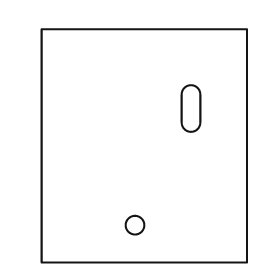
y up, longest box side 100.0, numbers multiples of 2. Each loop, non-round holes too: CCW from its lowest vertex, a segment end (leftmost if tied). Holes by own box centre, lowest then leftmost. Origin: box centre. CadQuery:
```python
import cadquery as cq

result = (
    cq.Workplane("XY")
    .moveTo(-44.0, -50.0)
    .lineTo(44.0, -50.0)
    .lineTo(44.0, 50.0)
    .lineTo(-44.0, 50.0)
    .close()
    .moveTo(-4.0, -34.0)
    .circle(4.0)
    .moveTo(16.0, 10.0)
    .threePointArc((20.0, 6.0), (24.0, 10.0))
    .lineTo(24.0, 22.0)
    .threePointArc((20.0, 26.0), (16.0, 22.0))
    .close()
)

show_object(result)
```